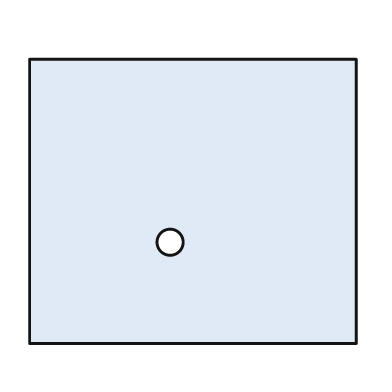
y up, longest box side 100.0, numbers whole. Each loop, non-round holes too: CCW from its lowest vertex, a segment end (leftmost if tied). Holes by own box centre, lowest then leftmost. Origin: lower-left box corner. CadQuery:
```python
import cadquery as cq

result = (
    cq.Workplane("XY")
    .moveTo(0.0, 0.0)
    .lineTo(100.0, 0.0)
    .lineTo(100.0, 87.0)
    .lineTo(0.0, 87.0)
    .close()
    .moveTo(43.0, 31.0)
    .circle(4.0)
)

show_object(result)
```